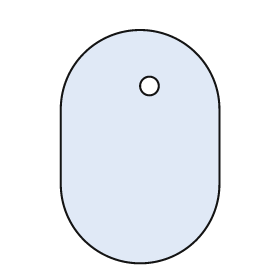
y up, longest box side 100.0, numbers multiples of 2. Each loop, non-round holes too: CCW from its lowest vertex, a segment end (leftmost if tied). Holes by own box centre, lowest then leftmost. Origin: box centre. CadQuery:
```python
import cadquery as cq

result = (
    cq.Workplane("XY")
    .moveTo(-34.0, -16.0)
    .threePointArc((0.0, -50.0), (34.0, -16.0))
    .lineTo(34.0, 16.0)
    .threePointArc((0.0, 50.0), (-34.0, 16.0))
    .close()
    .moveTo(4.0, 26.0)
    .circle(4.0)
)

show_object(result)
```